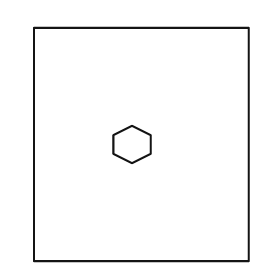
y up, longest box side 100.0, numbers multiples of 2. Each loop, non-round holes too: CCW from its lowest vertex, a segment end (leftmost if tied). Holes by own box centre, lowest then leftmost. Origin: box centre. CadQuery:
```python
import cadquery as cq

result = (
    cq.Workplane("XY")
    .moveTo(-46.0, -50.0)
    .lineTo(46.0, -50.0)
    .lineTo(46.0, 50.0)
    .lineTo(-46.0, 50.0)
    .close()
    .moveTo(-4.0, -8.0)
    .lineTo(4.0, -4.0)
    .lineTo(4.0, 4.0)
    .lineTo(-4.0, 8.0)
    .lineTo(-12.0, 4.0)
    .lineTo(-12.0, -4.0)
    .close()
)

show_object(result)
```